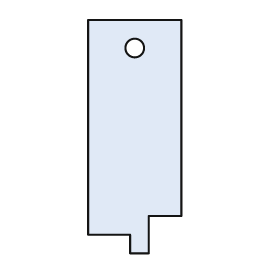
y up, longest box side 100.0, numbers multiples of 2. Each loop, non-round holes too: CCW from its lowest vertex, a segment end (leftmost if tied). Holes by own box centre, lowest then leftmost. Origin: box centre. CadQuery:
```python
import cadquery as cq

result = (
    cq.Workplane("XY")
    .moveTo(-2.0, -50.0)
    .lineTo(6.0, -50.0)
    .lineTo(6.0, -34.0)
    .lineTo(20.0, -34.0)
    .lineTo(20.0, 50.0)
    .lineTo(-20.0, 50.0)
    .lineTo(-20.0, -42.0)
    .lineTo(-2.0, -42.0)
    .close()
    .moveTo(0.0, 38.0)
    .circle(4.0)
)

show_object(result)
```